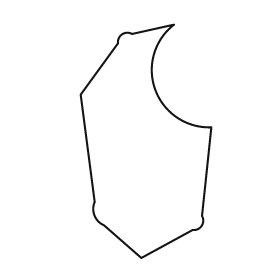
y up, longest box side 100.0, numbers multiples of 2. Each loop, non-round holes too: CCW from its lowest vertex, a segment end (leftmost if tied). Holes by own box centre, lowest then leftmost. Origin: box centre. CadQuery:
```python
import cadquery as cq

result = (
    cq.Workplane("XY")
    .moveTo(-2.0, -50.0)
    .lineTo(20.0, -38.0)
    .threePointArc((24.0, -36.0), (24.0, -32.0))
    .lineTo(28.0, 6.0)
    .threePointArc((4.0, 22.0), (12.0, 50.0))
    .lineTo(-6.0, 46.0)
    .threePointArc((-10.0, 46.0), (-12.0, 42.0))
    .lineTo(-28.0, 20.0)
    .lineTo(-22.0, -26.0)
    .threePointArc((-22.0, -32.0), (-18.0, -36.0))
    .close()
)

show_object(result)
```